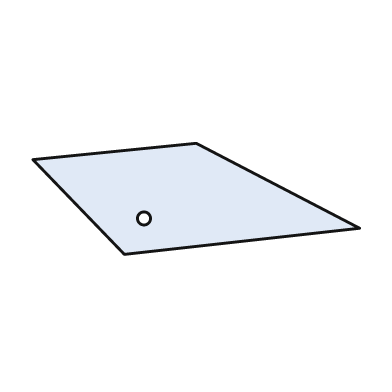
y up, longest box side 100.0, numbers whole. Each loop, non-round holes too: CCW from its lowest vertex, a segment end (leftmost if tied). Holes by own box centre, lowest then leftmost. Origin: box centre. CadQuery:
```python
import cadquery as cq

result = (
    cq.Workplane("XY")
    .moveTo(-22.0, -17.0)
    .lineTo(50.0, -9.0)
    .lineTo(0.0, 17.0)
    .lineTo(-50.0, 12.0)
    .close()
    .moveTo(-16.0, -6.0)
    .circle(2.0)
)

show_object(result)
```